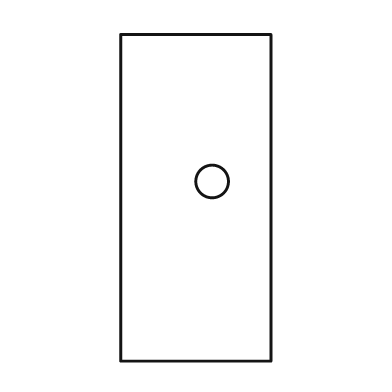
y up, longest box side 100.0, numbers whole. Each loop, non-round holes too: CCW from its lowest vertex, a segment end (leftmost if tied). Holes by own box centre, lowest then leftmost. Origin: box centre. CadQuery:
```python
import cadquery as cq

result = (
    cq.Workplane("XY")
    .moveTo(-23.0, -50.0)
    .lineTo(23.0, -50.0)
    .lineTo(23.0, 50.0)
    .lineTo(-23.0, 50.0)
    .close()
    .moveTo(5.0, 5.0)
    .circle(5.0)
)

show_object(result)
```